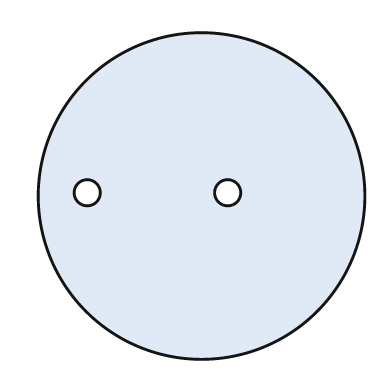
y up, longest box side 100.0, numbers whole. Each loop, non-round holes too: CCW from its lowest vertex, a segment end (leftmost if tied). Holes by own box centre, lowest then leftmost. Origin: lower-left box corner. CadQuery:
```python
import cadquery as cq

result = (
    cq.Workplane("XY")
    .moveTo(50.0, 50.0)
    .circle(50.0)
    .moveTo(15.0, 51.0)
    .circle(4.0)
    .moveTo(58.0, 51.0)
    .circle(4.0)
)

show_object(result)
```